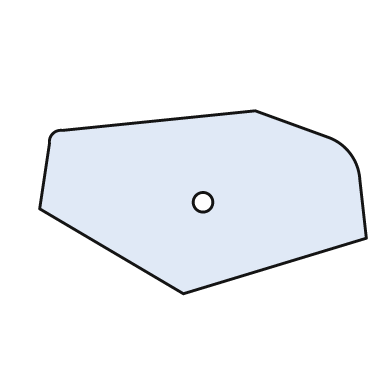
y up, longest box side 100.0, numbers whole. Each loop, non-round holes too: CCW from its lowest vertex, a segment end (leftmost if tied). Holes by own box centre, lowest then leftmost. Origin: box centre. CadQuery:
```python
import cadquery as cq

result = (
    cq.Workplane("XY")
    .moveTo(-6.0, -28.0)
    .lineTo(50.0, -11.0)
    .lineTo(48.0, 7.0)
    .threePointArc((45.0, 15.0), (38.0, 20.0))
    .lineTo(16.0, 28.0)
    .lineTo(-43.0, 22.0)
    .threePointArc((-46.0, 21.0), (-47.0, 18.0))
    .lineTo(-50.0, -2.0)
    .close()
    .moveTo(0.0, 0.0)
    .circle(3.0)
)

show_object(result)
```